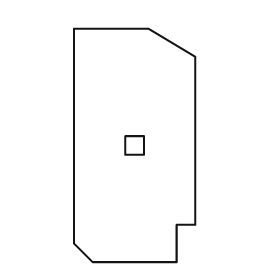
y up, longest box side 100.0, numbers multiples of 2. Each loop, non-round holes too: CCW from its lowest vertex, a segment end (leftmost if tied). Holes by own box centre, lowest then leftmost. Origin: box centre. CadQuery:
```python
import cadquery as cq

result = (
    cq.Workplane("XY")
    .moveTo(-18.0, -50.0)
    .lineTo(18.0, -50.0)
    .lineTo(18.0, -34.0)
    .lineTo(26.0, -34.0)
    .lineTo(26.0, 38.0)
    .lineTo(6.0, 50.0)
    .lineTo(-26.0, 50.0)
    .lineTo(-26.0, -42.0)
    .close()
    .moveTo(-4.0, -4.0)
    .lineTo(4.0, -4.0)
    .lineTo(4.0, 4.0)
    .lineTo(-4.0, 4.0)
    .close()
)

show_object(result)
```